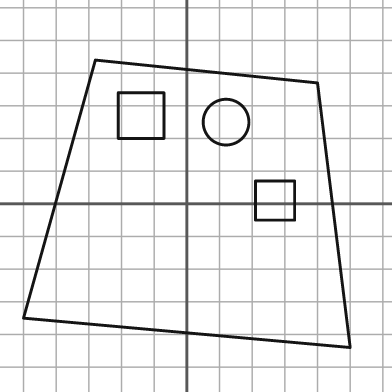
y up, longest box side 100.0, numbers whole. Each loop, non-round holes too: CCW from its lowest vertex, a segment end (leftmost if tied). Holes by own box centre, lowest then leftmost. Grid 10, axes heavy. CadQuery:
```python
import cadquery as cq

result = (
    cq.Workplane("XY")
    .moveTo(50.0, -44.0)
    .lineTo(40.0, 37.0)
    .lineTo(-28.0, 44.0)
    .lineTo(-50.0, -35.0)
    .close()
    .moveTo(21.0, -5.0)
    .lineTo(33.0, -5.0)
    .lineTo(33.0, 7.0)
    .lineTo(21.0, 7.0)
    .close()
    .moveTo(12.0, 25.0)
    .circle(7.0)
    .moveTo(-21.0, 20.0)
    .lineTo(-7.0, 20.0)
    .lineTo(-7.0, 34.0)
    .lineTo(-21.0, 34.0)
    .close()
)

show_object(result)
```